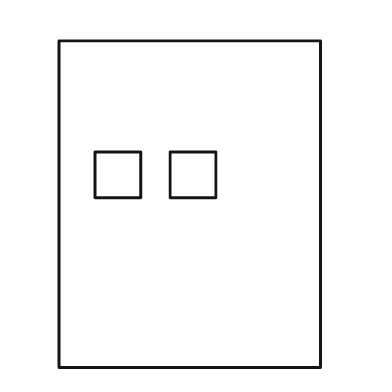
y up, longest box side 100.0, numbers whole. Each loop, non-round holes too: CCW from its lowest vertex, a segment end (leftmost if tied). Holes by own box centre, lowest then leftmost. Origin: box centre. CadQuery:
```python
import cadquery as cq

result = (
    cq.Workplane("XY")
    .moveTo(-40.0, -50.0)
    .lineTo(40.0, -50.0)
    .lineTo(40.0, 50.0)
    .lineTo(-40.0, 50.0)
    .close()
    .moveTo(-29.0, 2.0)
    .lineTo(-15.0, 2.0)
    .lineTo(-15.0, 16.0)
    .lineTo(-29.0, 16.0)
    .close()
    .moveTo(-6.0, 2.0)
    .lineTo(8.0, 2.0)
    .lineTo(8.0, 16.0)
    .lineTo(-6.0, 16.0)
    .close()
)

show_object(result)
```